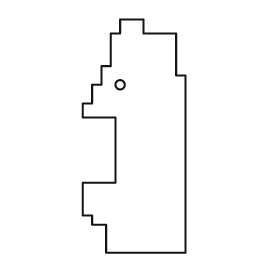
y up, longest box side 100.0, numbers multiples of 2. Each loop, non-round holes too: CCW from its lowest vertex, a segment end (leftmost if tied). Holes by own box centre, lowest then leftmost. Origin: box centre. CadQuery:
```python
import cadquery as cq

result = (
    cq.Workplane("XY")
    .moveTo(-12.0, -50.0)
    .lineTo(22.0, -50.0)
    .lineTo(22.0, 26.0)
    .lineTo(18.0, 26.0)
    .lineTo(18.0, 44.0)
    .lineTo(4.0, 44.0)
    .lineTo(4.0, 50.0)
    .lineTo(-6.0, 50.0)
    .lineTo(-6.0, 44.0)
    .lineTo(-10.0, 44.0)
    .lineTo(-10.0, 30.0)
    .lineTo(-14.0, 30.0)
    .lineTo(-14.0, 22.0)
    .lineTo(-18.0, 22.0)
    .lineTo(-18.0, 14.0)
    .lineTo(-22.0, 14.0)
    .lineTo(-22.0, 8.0)
    .lineTo(-8.0, 8.0)
    .lineTo(-8.0, -20.0)
    .lineTo(-22.0, -20.0)
    .lineTo(-22.0, -34.0)
    .lineTo(-18.0, -34.0)
    .lineTo(-18.0, -38.0)
    .lineTo(-12.0, -38.0)
    .close()
    .moveTo(-6.0, 22.0)
    .circle(2.0)
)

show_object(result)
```